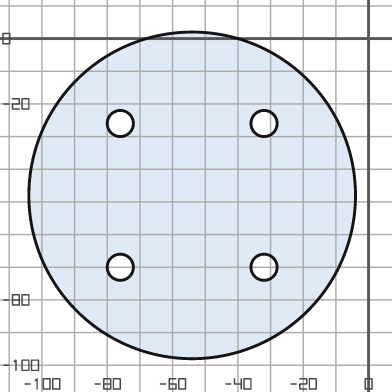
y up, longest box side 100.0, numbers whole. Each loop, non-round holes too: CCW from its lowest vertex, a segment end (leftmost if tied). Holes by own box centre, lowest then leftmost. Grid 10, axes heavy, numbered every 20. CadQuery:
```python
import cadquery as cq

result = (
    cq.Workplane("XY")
    .moveTo(-54.0, -48.0)
    .circle(50.0)
    .moveTo(-76.0, -70.0)
    .circle(4.0)
    .moveTo(-32.0, -70.0)
    .circle(4.0)
    .moveTo(-76.0, -26.0)
    .circle(4.0)
    .moveTo(-32.0, -26.0)
    .circle(4.0)
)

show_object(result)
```